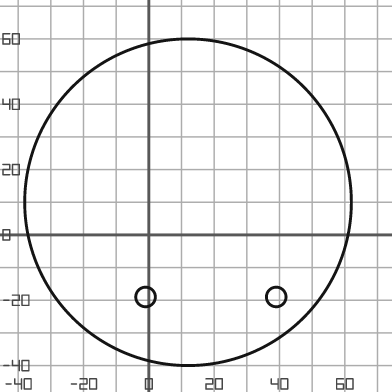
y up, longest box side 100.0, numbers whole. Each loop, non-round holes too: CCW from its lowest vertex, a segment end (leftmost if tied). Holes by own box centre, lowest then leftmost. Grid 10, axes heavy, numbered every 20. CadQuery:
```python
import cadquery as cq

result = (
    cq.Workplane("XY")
    .moveTo(12.0, 10.0)
    .circle(50.0)
    .moveTo(-1.0, -19.0)
    .circle(3.0)
    .moveTo(39.0, -19.0)
    .circle(3.0)
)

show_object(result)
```